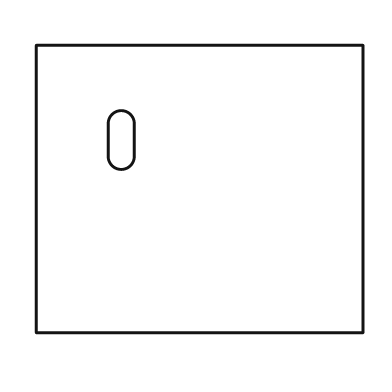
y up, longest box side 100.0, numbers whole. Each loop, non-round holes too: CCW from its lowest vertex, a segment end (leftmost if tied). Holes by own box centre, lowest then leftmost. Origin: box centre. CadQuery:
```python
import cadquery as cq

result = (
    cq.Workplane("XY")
    .moveTo(-50.0, -44.0)
    .lineTo(50.0, -44.0)
    .lineTo(50.0, 44.0)
    .lineTo(-50.0, 44.0)
    .close()
    .moveTo(-28.0, 10.0)
    .threePointArc((-24.0, 6.0), (-20.0, 10.0))
    .lineTo(-20.0, 20.0)
    .threePointArc((-24.0, 24.0), (-28.0, 20.0))
    .close()
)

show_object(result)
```